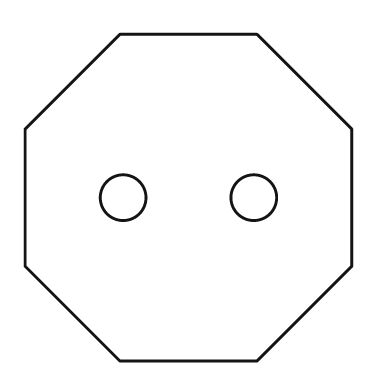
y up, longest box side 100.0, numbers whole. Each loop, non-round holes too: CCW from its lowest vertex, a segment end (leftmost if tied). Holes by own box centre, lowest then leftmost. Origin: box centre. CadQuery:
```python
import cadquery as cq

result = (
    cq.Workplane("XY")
    .moveTo(-21.0, -50.0)
    .lineTo(21.0, -50.0)
    .lineTo(50.0, -21.0)
    .lineTo(50.0, 21.0)
    .lineTo(21.0, 50.0)
    .lineTo(-21.0, 50.0)
    .lineTo(-50.0, 21.0)
    .lineTo(-50.0, -21.0)
    .close()
    .moveTo(-20.0, 0.0)
    .circle(7.0)
    .moveTo(20.0, 0.0)
    .circle(7.0)
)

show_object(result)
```